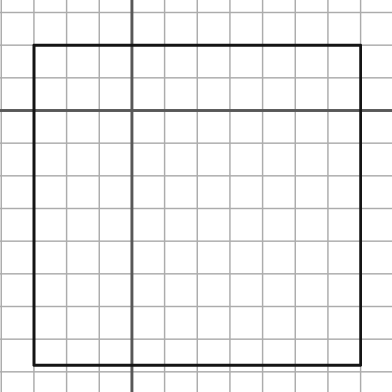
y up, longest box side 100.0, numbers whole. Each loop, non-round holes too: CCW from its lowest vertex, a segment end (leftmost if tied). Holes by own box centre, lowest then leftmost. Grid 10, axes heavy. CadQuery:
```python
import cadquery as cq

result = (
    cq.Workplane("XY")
    .moveTo(-30.0, -78.0)
    .lineTo(70.0, -78.0)
    .lineTo(70.0, 20.0)
    .lineTo(-30.0, 20.0)
    .close()
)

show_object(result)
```